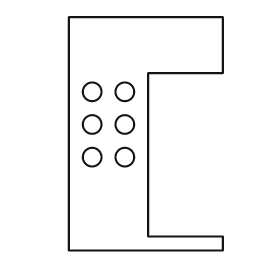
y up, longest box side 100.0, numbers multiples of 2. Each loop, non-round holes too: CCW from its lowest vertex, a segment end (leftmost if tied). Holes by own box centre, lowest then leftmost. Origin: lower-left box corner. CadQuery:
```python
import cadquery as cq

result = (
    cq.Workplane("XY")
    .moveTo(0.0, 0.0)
    .lineTo(66.0, 0.0)
    .lineTo(66.0, 6.0)
    .lineTo(34.0, 6.0)
    .lineTo(34.0, 76.0)
    .lineTo(66.0, 76.0)
    .lineTo(66.0, 100.0)
    .lineTo(0.0, 100.0)
    .close()
    .moveTo(10.0, 40.0)
    .circle(4.0)
    .moveTo(24.0, 40.0)
    .circle(4.0)
    .moveTo(10.0, 54.0)
    .circle(4.0)
    .moveTo(24.0, 54.0)
    .circle(4.0)
    .moveTo(10.0, 68.0)
    .circle(4.0)
    .moveTo(24.0, 68.0)
    .circle(4.0)
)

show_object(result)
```